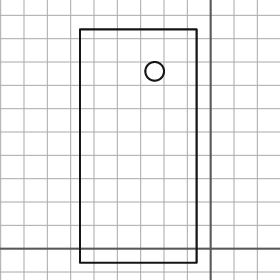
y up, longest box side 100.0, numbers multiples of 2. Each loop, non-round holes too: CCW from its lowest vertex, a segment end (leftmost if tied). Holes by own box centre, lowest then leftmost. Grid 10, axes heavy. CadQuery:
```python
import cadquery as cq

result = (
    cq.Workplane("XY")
    .moveTo(-56.0, -6.0)
    .lineTo(-6.0, -6.0)
    .lineTo(-6.0, 94.0)
    .lineTo(-56.0, 94.0)
    .close()
    .moveTo(-24.0, 76.0)
    .circle(4.0)
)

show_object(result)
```